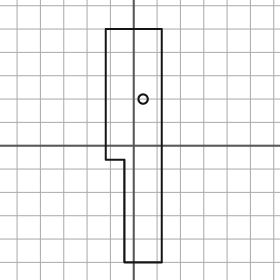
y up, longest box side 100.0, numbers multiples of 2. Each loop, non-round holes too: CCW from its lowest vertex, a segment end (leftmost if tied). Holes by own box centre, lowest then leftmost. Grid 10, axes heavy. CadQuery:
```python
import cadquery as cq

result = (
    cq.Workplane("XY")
    .moveTo(-4.0, -50.0)
    .lineTo(12.0, -50.0)
    .lineTo(12.0, 50.0)
    .lineTo(-12.0, 50.0)
    .lineTo(-12.0, -6.0)
    .lineTo(-4.0, -6.0)
    .close()
    .moveTo(4.0, 20.0)
    .circle(2.0)
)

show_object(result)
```